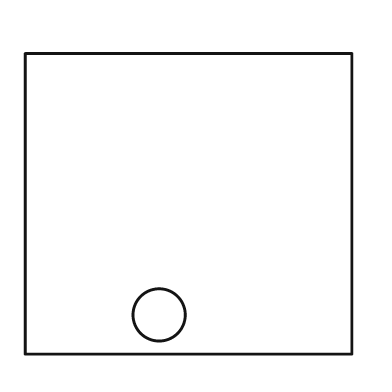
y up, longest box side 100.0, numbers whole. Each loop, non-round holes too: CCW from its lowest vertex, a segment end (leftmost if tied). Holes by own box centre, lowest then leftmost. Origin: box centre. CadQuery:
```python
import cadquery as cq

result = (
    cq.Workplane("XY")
    .moveTo(-50.0, -46.0)
    .lineTo(50.0, -46.0)
    .lineTo(50.0, 46.0)
    .lineTo(-50.0, 46.0)
    .close()
    .moveTo(-9.0, -34.0)
    .circle(8.0)
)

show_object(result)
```